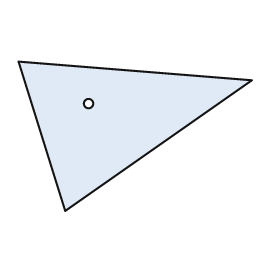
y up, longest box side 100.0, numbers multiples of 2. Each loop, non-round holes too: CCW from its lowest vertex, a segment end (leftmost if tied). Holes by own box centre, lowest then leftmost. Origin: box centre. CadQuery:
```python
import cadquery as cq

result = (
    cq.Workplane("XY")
    .moveTo(-30.0, -32.0)
    .lineTo(50.0, 24.0)
    .lineTo(-50.0, 32.0)
    .close()
    .moveTo(-20.0, 14.0)
    .circle(2.0)
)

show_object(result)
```